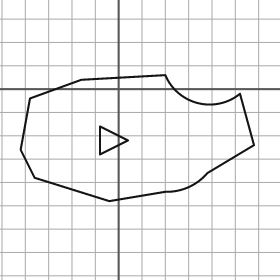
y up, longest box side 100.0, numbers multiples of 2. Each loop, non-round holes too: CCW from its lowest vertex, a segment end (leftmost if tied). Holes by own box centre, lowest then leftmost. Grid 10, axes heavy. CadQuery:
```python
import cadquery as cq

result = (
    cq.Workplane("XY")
    .moveTo(-4.0, -48.0)
    .lineTo(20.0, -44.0)
    .threePointArc((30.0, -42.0), (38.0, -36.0))
    .lineTo(58.0, -24.0)
    .lineTo(52.0, -2.0)
    .threePointArc((34.0, -6.0), (20.0, 6.0))
    .lineTo(-16.0, 4.0)
    .lineTo(-38.0, -4.0)
    .lineTo(-42.0, -26.0)
    .lineTo(-36.0, -38.0)
    .close()
    .moveTo(-8.0, -28.0)
    .lineTo(4.0, -22.0)
    .lineTo(-8.0, -16.0)
    .close()
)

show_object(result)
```